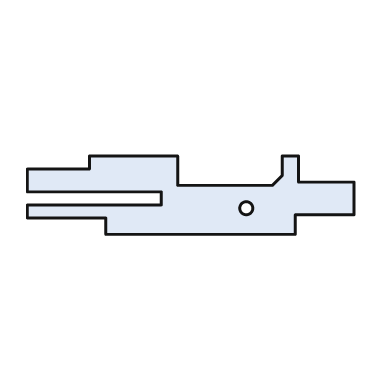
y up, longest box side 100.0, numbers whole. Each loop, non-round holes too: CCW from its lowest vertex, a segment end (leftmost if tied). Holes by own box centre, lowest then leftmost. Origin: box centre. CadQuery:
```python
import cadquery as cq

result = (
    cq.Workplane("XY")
    .moveTo(-26.0, -12.0)
    .lineTo(32.0, -12.0)
    .lineTo(32.0, -6.0)
    .lineTo(50.0, -6.0)
    .lineTo(50.0, 4.0)
    .lineTo(33.0, 4.0)
    .lineTo(33.0, 12.0)
    .lineTo(28.0, 12.0)
    .lineTo(28.0, 6.0)
    .lineTo(25.0, 3.0)
    .lineTo(-4.0, 3.0)
    .lineTo(-4.0, 12.0)
    .lineTo(-31.0, 12.0)
    .lineTo(-31.0, 8.0)
    .lineTo(-50.0, 8.0)
    .lineTo(-50.0, 1.0)
    .lineTo(-9.0, 1.0)
    .lineTo(-9.0, -3.0)
    .lineTo(-50.0, -3.0)
    .lineTo(-50.0, -7.0)
    .lineTo(-26.0, -7.0)
    .close()
    .moveTo(17.0, -4.0)
    .circle(2.0)
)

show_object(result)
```